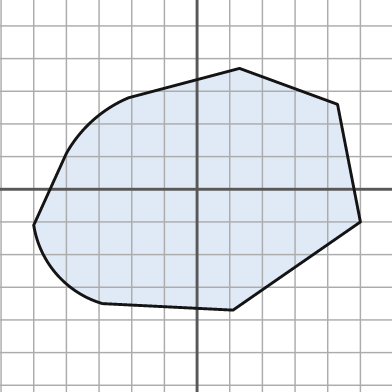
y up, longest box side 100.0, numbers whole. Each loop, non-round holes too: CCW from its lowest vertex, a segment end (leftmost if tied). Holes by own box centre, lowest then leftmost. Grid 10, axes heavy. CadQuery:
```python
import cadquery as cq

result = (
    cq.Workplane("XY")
    .moveTo(11.0, -37.0)
    .lineTo(50.0, -10.0)
    .lineTo(43.0, 26.0)
    .lineTo(13.0, 37.0)
    .lineTo(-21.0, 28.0)
    .threePointArc((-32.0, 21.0), (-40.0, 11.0))
    .lineTo(-50.0, -11.0)
    .threePointArc((-43.0, -26.0), (-29.0, -35.0))
    .close()
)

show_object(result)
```